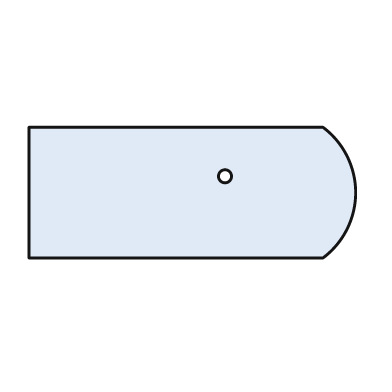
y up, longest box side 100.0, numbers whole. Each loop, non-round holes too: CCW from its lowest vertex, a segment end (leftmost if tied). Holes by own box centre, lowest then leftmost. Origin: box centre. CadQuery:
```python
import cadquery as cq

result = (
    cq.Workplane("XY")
    .moveTo(-50.0, -20.0)
    .lineTo(40.0, -20.0)
    .threePointArc((50.0, 0.0), (40.0, 20.0))
    .lineTo(-50.0, 20.0)
    .close()
    .moveTo(10.0, 5.0)
    .circle(2.0)
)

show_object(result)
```